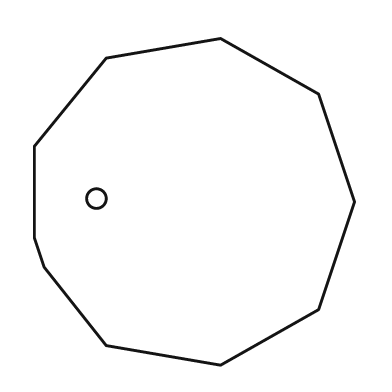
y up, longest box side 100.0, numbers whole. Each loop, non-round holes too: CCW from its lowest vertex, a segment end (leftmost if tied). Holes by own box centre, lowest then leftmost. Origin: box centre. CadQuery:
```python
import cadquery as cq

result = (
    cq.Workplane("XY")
    .moveTo(8.0, -50.0)
    .lineTo(38.0, -33.0)
    .lineTo(49.0, 0.0)
    .lineTo(38.0, 33.0)
    .lineTo(8.0, 50.0)
    .lineTo(-27.0, 44.0)
    .lineTo(-49.0, 17.0)
    .lineTo(-49.0, -11.0)
    .lineTo(-46.0, -20.0)
    .lineTo(-27.0, -44.0)
    .close()
    .moveTo(-30.0, 1.0)
    .circle(3.0)
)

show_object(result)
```